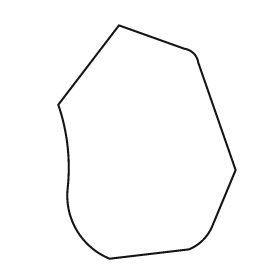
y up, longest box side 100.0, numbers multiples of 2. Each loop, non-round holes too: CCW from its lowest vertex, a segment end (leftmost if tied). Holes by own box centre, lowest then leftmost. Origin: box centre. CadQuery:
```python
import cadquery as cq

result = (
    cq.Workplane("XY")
    .moveTo(-16.0, -50.0)
    .lineTo(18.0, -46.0)
    .threePointArc((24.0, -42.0), (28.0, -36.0))
    .lineTo(38.0, -12.0)
    .lineTo(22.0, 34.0)
    .threePointArc((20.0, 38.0), (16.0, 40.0))
    .lineTo(-12.0, 50.0)
    .lineTo(-38.0, 16.0)
    .threePointArc((-34.0, -2.0), (-34.0, -20.0))
    .threePointArc((-30.0, -38.0), (-16.0, -50.0))
    .close()
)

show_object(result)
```